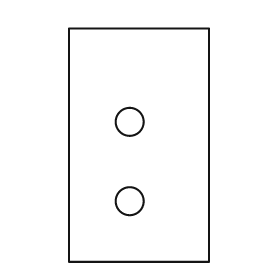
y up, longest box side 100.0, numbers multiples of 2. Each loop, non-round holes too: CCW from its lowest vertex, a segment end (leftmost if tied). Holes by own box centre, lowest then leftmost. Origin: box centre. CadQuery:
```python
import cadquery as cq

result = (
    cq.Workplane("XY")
    .moveTo(-30.0, -50.0)
    .lineTo(30.0, -50.0)
    .lineTo(30.0, 50.0)
    .lineTo(-30.0, 50.0)
    .close()
    .moveTo(-4.0, -24.0)
    .circle(6.0)
    .moveTo(-4.0, 10.0)
    .circle(6.0)
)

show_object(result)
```